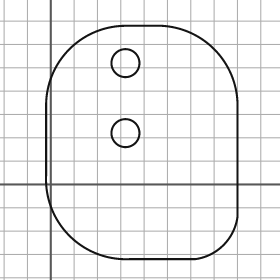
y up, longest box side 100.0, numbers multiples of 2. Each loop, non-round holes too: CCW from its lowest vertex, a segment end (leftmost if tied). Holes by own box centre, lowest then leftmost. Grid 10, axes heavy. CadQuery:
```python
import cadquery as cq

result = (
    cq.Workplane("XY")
    .moveTo(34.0, -32.0)
    .lineTo(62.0, -32.0)
    .threePointArc((74.0, -26.0), (80.0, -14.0))
    .lineTo(80.0, 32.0)
    .threePointArc((70.0, 58.0), (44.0, 68.0))
    .lineTo(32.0, 68.0)
    .threePointArc((8.0, 58.0), (-2.0, 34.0))
    .lineTo(-2.0, 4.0)
    .threePointArc((8.0, -22.0), (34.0, -32.0))
    .close()
    .moveTo(32.0, 22.0)
    .circle(6.0)
    .moveTo(32.0, 52.0)
    .circle(6.0)
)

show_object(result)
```